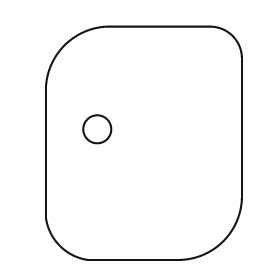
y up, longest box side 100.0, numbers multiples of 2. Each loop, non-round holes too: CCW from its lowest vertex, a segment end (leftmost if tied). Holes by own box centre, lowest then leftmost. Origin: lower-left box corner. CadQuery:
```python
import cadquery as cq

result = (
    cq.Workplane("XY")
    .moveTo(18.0, 0.0)
    .lineTo(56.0, 0.0)
    .threePointArc((76.0, 8.0), (84.0, 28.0))
    .lineTo(84.0, 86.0)
    .threePointArc((80.0, 96.0), (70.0, 100.0))
    .lineTo(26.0, 100.0)
    .threePointArc((8.0, 92.0), (0.0, 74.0))
    .lineTo(0.0, 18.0)
    .threePointArc((6.0, 6.0), (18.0, 0.0))
    .close()
    .moveTo(22.0, 56.0)
    .circle(6.0)
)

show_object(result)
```